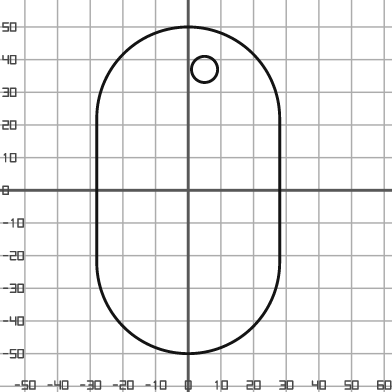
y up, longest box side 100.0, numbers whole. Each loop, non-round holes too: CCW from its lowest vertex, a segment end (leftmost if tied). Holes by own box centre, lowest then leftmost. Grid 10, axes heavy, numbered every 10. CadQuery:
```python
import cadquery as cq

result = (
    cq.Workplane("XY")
    .moveTo(-28.0, -22.0)
    .threePointArc((0.0, -50.0), (28.0, -22.0))
    .lineTo(28.0, 22.0)
    .threePointArc((0.0, 50.0), (-28.0, 22.0))
    .close()
    .moveTo(5.0, 37.0)
    .circle(4.0)
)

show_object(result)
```